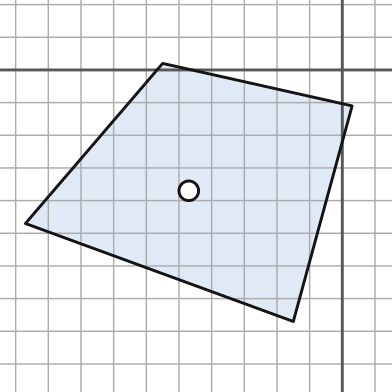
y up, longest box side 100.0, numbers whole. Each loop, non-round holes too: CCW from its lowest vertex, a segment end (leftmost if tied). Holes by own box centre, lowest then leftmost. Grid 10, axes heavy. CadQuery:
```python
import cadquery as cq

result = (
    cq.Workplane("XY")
    .moveTo(-15.0, -77.0)
    .lineTo(3.0, -11.0)
    .lineTo(-55.0, 2.0)
    .lineTo(-97.0, -47.0)
    .close()
    .moveTo(-47.0, -37.0)
    .circle(3.0)
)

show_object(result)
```